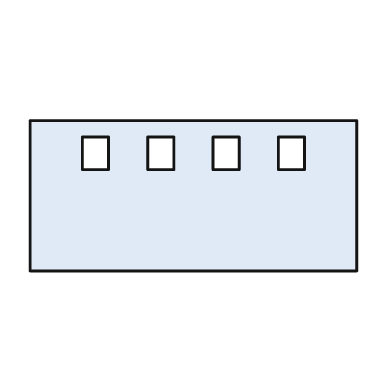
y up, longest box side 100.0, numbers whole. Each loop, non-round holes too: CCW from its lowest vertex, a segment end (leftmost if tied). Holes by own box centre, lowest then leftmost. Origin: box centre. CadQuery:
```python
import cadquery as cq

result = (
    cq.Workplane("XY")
    .moveTo(-50.0, -23.0)
    .lineTo(50.0, -23.0)
    .lineTo(50.0, 23.0)
    .lineTo(-50.0, 23.0)
    .close()
    .moveTo(-34.0, 8.0)
    .lineTo(-26.0, 8.0)
    .lineTo(-26.0, 18.0)
    .lineTo(-34.0, 18.0)
    .close()
    .moveTo(-14.0, 8.0)
    .lineTo(-6.0, 8.0)
    .lineTo(-6.0, 18.0)
    .lineTo(-14.0, 18.0)
    .close()
    .moveTo(6.0, 8.0)
    .lineTo(14.0, 8.0)
    .lineTo(14.0, 18.0)
    .lineTo(6.0, 18.0)
    .close()
    .moveTo(26.0, 8.0)
    .lineTo(34.0, 8.0)
    .lineTo(34.0, 18.0)
    .lineTo(26.0, 18.0)
    .close()
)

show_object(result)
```